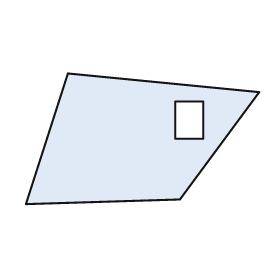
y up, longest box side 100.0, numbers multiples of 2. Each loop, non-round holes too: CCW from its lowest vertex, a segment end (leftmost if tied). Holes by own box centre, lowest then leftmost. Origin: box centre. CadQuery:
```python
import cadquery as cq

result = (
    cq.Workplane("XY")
    .moveTo(-50.0, -28.0)
    .lineTo(16.0, -26.0)
    .lineTo(50.0, 20.0)
    .lineTo(-32.0, 28.0)
    .close()
    .moveTo(14.0, 0.0)
    .lineTo(26.0, 0.0)
    .lineTo(26.0, 16.0)
    .lineTo(14.0, 16.0)
    .close()
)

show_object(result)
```